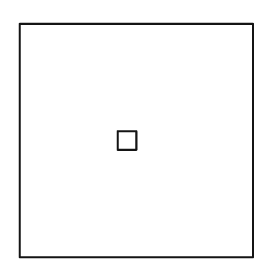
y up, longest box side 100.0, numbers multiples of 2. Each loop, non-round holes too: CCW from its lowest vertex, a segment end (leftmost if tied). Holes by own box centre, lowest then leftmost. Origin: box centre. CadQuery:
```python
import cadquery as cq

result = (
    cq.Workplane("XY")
    .moveTo(-50.0, -50.0)
    .lineTo(50.0, -50.0)
    .lineTo(50.0, 50.0)
    .lineTo(-50.0, 50.0)
    .close()
    .moveTo(-8.0, -4.0)
    .lineTo(0.0, -4.0)
    .lineTo(0.0, 4.0)
    .lineTo(-8.0, 4.0)
    .close()
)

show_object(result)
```